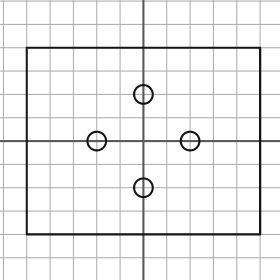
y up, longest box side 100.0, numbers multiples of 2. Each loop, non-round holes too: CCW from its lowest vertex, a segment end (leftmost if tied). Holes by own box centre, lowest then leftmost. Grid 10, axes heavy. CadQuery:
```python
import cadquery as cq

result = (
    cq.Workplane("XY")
    .moveTo(-50.0, -40.0)
    .lineTo(50.0, -40.0)
    .lineTo(50.0, 40.0)
    .lineTo(-50.0, 40.0)
    .close()
    .moveTo(0.0, -20.0)
    .circle(4.0)
    .moveTo(-20.0, 0.0)
    .circle(4.0)
    .moveTo(20.0, 0.0)
    .circle(4.0)
    .moveTo(0.0, 20.0)
    .circle(4.0)
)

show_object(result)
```